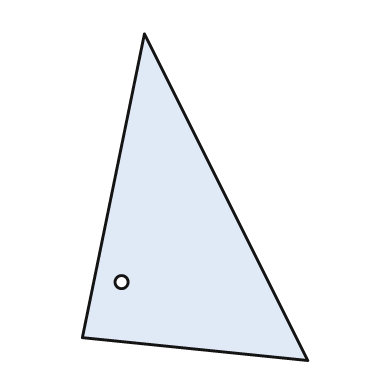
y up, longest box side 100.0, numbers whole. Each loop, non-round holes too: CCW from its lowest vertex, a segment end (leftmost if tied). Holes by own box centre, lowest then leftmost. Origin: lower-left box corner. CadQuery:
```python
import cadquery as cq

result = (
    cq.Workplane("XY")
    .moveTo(69.0, 0.0)
    .lineTo(19.0, 100.0)
    .lineTo(0.0, 7.0)
    .close()
    .moveTo(12.0, 24.0)
    .circle(2.0)
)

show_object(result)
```